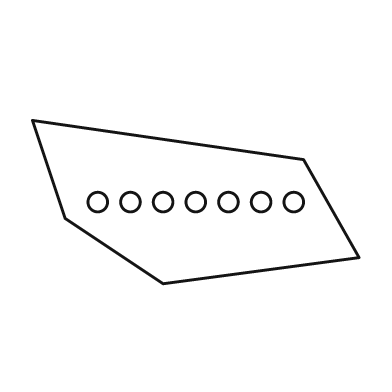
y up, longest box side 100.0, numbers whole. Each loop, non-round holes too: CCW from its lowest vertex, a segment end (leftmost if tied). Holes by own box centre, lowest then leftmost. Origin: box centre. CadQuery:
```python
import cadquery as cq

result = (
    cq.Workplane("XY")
    .moveTo(-10.0, -25.0)
    .lineTo(50.0, -17.0)
    .lineTo(33.0, 13.0)
    .lineTo(-50.0, 25.0)
    .lineTo(-40.0, -5.0)
    .close()
    .moveTo(-30.0, 0.0)
    .circle(3.0)
    .moveTo(-20.0, 0.0)
    .circle(3.0)
    .moveTo(-10.0, 0.0)
    .circle(3.0)
    .moveTo(0.0, 0.0)
    .circle(3.0)
    .moveTo(10.0, 0.0)
    .circle(3.0)
    .moveTo(20.0, 0.0)
    .circle(3.0)
    .moveTo(30.0, 0.0)
    .circle(3.0)
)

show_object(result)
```